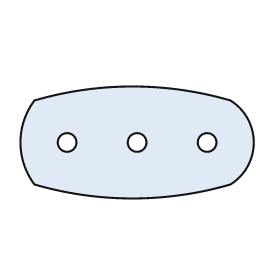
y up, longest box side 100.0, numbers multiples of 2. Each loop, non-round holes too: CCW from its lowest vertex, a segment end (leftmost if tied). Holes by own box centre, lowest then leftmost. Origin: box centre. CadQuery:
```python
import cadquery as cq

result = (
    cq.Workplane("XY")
    .moveTo(-44.0, -18.0)
    .threePointArc((-2.0, -24.0), (40.0, -18.0))
    .threePointArc((50.0, 0.0), (40.0, 18.0))
    .threePointArc((-2.0, 24.0), (-44.0, 18.0))
    .threePointArc((-50.0, 0.0), (-44.0, -18.0))
    .close()
    .moveTo(-30.0, 0.0)
    .circle(4.0)
    .moveTo(0.0, 0.0)
    .circle(4.0)
    .moveTo(30.0, 0.0)
    .circle(4.0)
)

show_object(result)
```